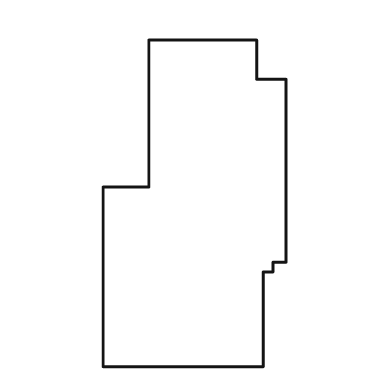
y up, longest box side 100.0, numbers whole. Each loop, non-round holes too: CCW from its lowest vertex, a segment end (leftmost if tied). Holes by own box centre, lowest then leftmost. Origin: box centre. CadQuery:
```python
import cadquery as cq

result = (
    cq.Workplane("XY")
    .moveTo(-28.0, -50.0)
    .lineTo(21.0, -50.0)
    .lineTo(21.0, -21.0)
    .lineTo(24.0, -21.0)
    .lineTo(24.0, -18.0)
    .lineTo(28.0, -18.0)
    .lineTo(28.0, 38.0)
    .lineTo(19.0, 38.0)
    .lineTo(19.0, 50.0)
    .lineTo(-14.0, 50.0)
    .lineTo(-14.0, 5.0)
    .lineTo(-28.0, 5.0)
    .close()
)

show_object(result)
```